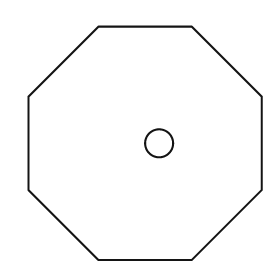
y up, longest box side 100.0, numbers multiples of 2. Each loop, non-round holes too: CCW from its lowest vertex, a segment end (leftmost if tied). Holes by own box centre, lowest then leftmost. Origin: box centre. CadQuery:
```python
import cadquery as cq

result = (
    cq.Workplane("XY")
    .moveTo(-20.0, -50.0)
    .lineTo(20.0, -50.0)
    .lineTo(50.0, -20.0)
    .lineTo(50.0, 20.0)
    .lineTo(20.0, 50.0)
    .lineTo(-20.0, 50.0)
    .lineTo(-50.0, 20.0)
    .lineTo(-50.0, -20.0)
    .close()
    .moveTo(6.0, 0.0)
    .circle(6.0)
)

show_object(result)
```